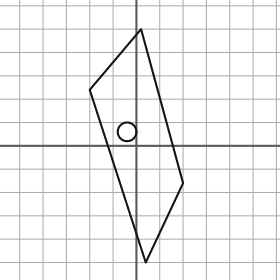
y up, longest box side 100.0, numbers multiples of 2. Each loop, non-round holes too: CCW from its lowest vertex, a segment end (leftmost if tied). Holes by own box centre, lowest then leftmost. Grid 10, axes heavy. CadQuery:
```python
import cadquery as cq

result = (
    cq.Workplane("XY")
    .moveTo(4.0, -50.0)
    .lineTo(20.0, -16.0)
    .lineTo(2.0, 50.0)
    .lineTo(-20.0, 24.0)
    .close()
    .moveTo(-4.0, 6.0)
    .circle(4.0)
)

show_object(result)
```